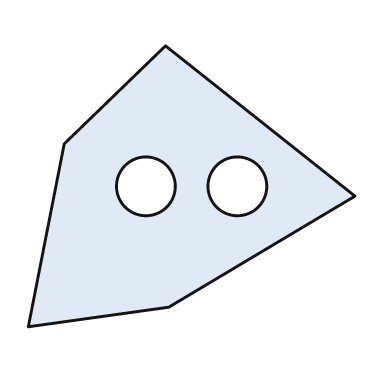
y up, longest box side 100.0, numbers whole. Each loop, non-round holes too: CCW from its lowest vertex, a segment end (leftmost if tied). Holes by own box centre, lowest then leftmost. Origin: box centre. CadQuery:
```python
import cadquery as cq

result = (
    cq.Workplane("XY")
    .moveTo(-50.0, -43.0)
    .lineTo(-7.0, -37.0)
    .lineTo(50.0, -3.0)
    .lineTo(-8.0, 43.0)
    .lineTo(-39.0, 13.0)
    .close()
    .moveTo(-14.0, 0.0)
    .circle(9.0)
    .moveTo(14.0, 0.0)
    .circle(9.0)
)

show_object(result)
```